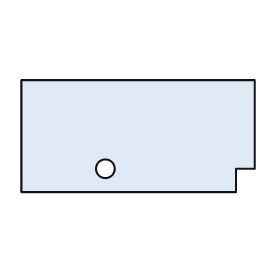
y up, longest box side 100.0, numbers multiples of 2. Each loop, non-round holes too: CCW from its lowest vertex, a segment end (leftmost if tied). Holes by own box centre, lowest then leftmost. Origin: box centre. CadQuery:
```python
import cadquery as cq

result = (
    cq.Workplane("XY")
    .moveTo(-50.0, -24.0)
    .lineTo(42.0, -24.0)
    .lineTo(42.0, -14.0)
    .lineTo(50.0, -14.0)
    .lineTo(50.0, 24.0)
    .lineTo(-50.0, 24.0)
    .close()
    .moveTo(-14.0, -14.0)
    .circle(4.0)
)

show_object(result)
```